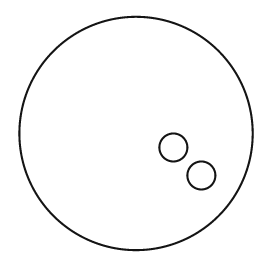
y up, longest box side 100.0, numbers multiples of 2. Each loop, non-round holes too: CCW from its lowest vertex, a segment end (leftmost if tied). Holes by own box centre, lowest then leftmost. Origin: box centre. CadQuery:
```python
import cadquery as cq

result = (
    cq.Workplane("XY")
    .moveTo(0.0, 0.0)
    .circle(50.0)
    .moveTo(28.0, -18.0)
    .circle(6.0)
    .moveTo(16.0, -6.0)
    .circle(6.0)
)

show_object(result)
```